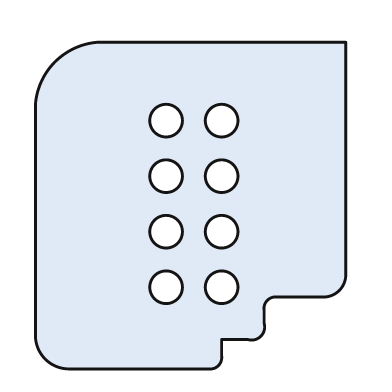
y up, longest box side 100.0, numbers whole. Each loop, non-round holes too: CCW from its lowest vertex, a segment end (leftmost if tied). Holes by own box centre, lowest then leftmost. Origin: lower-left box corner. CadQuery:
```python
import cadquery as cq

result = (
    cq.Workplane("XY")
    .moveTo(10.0, 0.0)
    .lineTo(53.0, 0.0)
    .threePointArc((56.0, 1.0), (57.0, 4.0))
    .lineTo(57.0, 9.0)
    .lineTo(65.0, 9.0)
    .threePointArc((69.0, 10.0), (70.0, 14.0))
    .lineTo(70.0, 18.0)
    .threePointArc((71.0, 21.0), (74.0, 22.0))
    .lineTo(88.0, 22.0)
    .threePointArc((93.0, 24.0), (95.0, 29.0))
    .lineTo(95.0, 100.0)
    .lineTo(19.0, 100.0)
    .threePointArc((6.0, 94.0), (0.0, 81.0))
    .lineTo(0.0, 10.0)
    .threePointArc((3.0, 3.0), (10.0, 0.0))
    .close()
    .moveTo(40.0, 25.0)
    .circle(5.0)
    .moveTo(57.0, 25.0)
    .circle(5.0)
    .moveTo(40.0, 42.0)
    .circle(5.0)
    .moveTo(57.0, 42.0)
    .circle(5.0)
    .moveTo(40.0, 59.0)
    .circle(5.0)
    .moveTo(57.0, 59.0)
    .circle(5.0)
    .moveTo(40.0, 76.0)
    .circle(5.0)
    .moveTo(57.0, 76.0)
    .circle(5.0)
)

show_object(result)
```